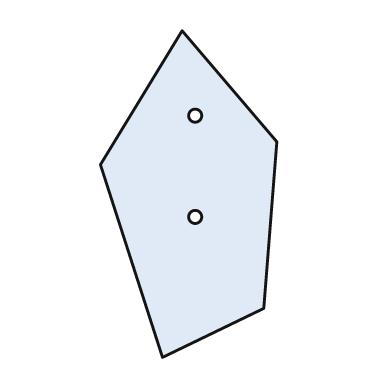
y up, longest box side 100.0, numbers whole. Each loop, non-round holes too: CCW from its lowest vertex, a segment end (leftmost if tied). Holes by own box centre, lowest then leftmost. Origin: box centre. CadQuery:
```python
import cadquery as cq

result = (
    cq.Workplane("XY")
    .moveTo(-8.0, -50.0)
    .lineTo(23.0, -35.0)
    .lineTo(27.0, 16.0)
    .lineTo(-2.0, 50.0)
    .lineTo(-27.0, 9.0)
    .close()
    .moveTo(2.0, -7.0)
    .circle(2.0)
    .moveTo(2.0, 24.0)
    .circle(2.0)
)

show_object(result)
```